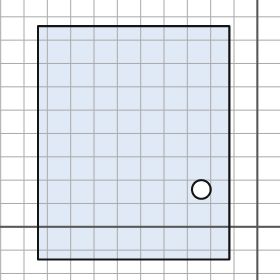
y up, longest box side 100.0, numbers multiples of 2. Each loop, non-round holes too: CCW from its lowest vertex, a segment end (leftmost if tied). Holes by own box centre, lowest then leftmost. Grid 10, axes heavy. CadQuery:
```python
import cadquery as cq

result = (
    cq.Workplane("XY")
    .moveTo(-94.0, -14.0)
    .lineTo(-12.0, -14.0)
    .lineTo(-12.0, 86.0)
    .lineTo(-94.0, 86.0)
    .close()
    .moveTo(-24.0, 16.0)
    .circle(4.0)
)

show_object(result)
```